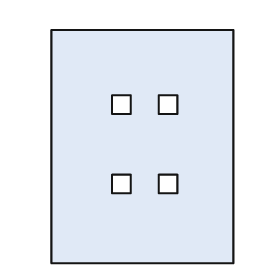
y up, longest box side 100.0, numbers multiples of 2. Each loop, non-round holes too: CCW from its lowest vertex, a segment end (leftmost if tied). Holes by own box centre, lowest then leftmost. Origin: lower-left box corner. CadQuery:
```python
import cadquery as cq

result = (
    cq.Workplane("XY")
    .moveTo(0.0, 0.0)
    .lineTo(78.0, 0.0)
    .lineTo(78.0, 100.0)
    .lineTo(0.0, 100.0)
    .close()
    .moveTo(26.0, 30.0)
    .lineTo(34.0, 30.0)
    .lineTo(34.0, 38.0)
    .lineTo(26.0, 38.0)
    .close()
    .moveTo(46.0, 30.0)
    .lineTo(54.0, 30.0)
    .lineTo(54.0, 38.0)
    .lineTo(46.0, 38.0)
    .close()
    .moveTo(26.0, 64.0)
    .lineTo(34.0, 64.0)
    .lineTo(34.0, 72.0)
    .lineTo(26.0, 72.0)
    .close()
    .moveTo(46.0, 64.0)
    .lineTo(54.0, 64.0)
    .lineTo(54.0, 72.0)
    .lineTo(46.0, 72.0)
    .close()
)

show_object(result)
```